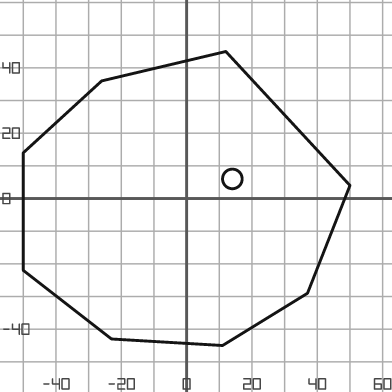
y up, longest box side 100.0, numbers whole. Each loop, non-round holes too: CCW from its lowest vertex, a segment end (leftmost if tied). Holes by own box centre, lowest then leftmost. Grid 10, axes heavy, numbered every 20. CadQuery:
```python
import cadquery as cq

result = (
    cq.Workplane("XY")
    .moveTo(11.0, -45.0)
    .lineTo(37.0, -29.0)
    .lineTo(50.0, 4.0)
    .lineTo(12.0, 45.0)
    .lineTo(-26.0, 36.0)
    .lineTo(-50.0, 14.0)
    .lineTo(-50.0, -22.0)
    .lineTo(-23.0, -43.0)
    .close()
    .moveTo(14.0, 6.0)
    .circle(3.0)
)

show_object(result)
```